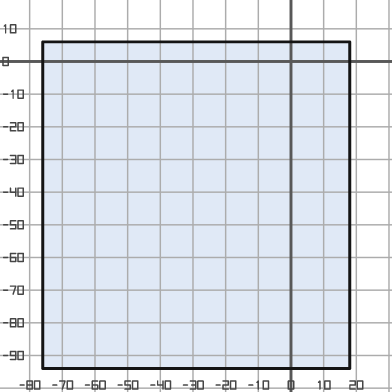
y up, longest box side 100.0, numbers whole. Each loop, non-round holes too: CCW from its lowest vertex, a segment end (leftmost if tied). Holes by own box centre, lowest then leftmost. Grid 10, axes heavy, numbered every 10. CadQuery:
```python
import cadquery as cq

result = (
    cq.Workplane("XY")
    .moveTo(-76.0, -94.0)
    .lineTo(18.0, -94.0)
    .lineTo(18.0, 6.0)
    .lineTo(-76.0, 6.0)
    .close()
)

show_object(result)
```